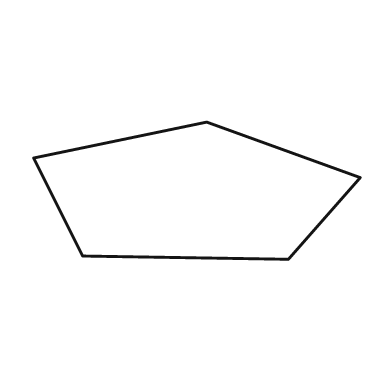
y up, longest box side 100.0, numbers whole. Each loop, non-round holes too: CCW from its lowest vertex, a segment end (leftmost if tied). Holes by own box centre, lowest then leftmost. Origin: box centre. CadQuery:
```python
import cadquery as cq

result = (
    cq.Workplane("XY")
    .moveTo(28.0, -21.0)
    .lineTo(50.0, 4.0)
    .lineTo(3.0, 21.0)
    .lineTo(-50.0, 10.0)
    .lineTo(-35.0, -20.0)
    .close()
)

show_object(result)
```